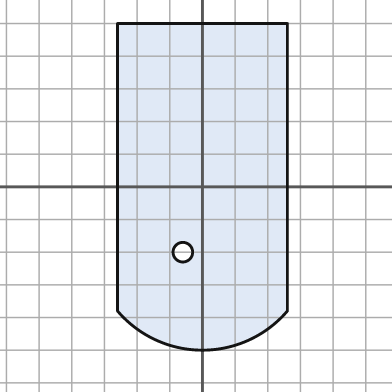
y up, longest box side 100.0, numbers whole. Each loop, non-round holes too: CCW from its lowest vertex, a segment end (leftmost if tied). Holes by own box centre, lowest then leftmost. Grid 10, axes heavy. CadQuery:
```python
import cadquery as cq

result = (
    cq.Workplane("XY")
    .moveTo(-26.0, -38.0)
    .threePointArc((0.0, -50.0), (26.0, -38.0))
    .lineTo(26.0, 50.0)
    .lineTo(-26.0, 50.0)
    .close()
    .moveTo(-6.0, -20.0)
    .circle(3.0)
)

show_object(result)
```